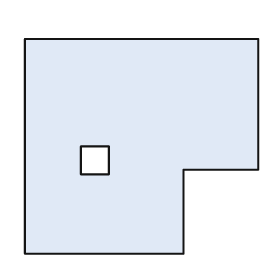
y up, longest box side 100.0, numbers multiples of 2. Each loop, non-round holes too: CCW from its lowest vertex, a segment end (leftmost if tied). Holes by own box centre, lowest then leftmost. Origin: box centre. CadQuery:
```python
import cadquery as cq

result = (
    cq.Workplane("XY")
    .moveTo(-50.0, -46.0)
    .lineTo(18.0, -46.0)
    .lineTo(18.0, -10.0)
    .lineTo(50.0, -10.0)
    .lineTo(50.0, 46.0)
    .lineTo(-50.0, 46.0)
    .close()
    .moveTo(-26.0, -12.0)
    .lineTo(-14.0, -12.0)
    .lineTo(-14.0, 0.0)
    .lineTo(-26.0, 0.0)
    .close()
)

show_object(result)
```